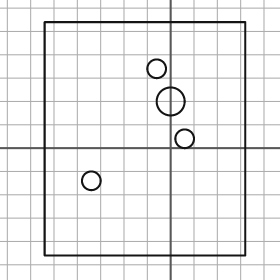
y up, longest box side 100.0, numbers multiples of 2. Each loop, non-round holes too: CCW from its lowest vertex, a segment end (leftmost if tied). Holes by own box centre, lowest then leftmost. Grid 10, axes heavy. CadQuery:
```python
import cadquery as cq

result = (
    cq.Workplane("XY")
    .moveTo(-54.0, -46.0)
    .lineTo(32.0, -46.0)
    .lineTo(32.0, 54.0)
    .lineTo(-54.0, 54.0)
    .close()
    .moveTo(-34.0, -14.0)
    .circle(4.0)
    .moveTo(6.0, 4.0)
    .circle(4.0)
    .moveTo(0.0, 20.0)
    .circle(6.0)
    .moveTo(-6.0, 34.0)
    .circle(4.0)
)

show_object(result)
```